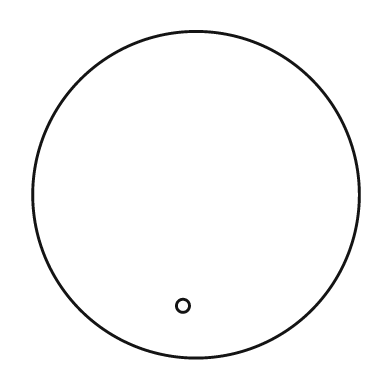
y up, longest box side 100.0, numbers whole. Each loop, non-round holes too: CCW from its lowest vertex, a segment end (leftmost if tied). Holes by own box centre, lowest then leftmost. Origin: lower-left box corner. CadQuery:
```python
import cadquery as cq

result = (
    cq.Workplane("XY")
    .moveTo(50.0, 50.0)
    .circle(50.0)
    .moveTo(46.0, 16.0)
    .circle(2.0)
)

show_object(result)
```